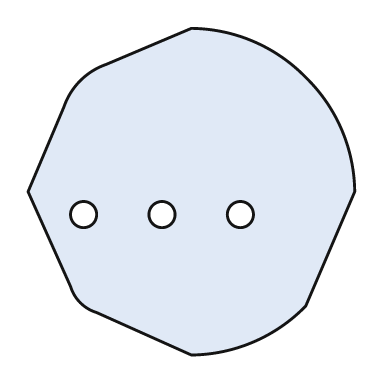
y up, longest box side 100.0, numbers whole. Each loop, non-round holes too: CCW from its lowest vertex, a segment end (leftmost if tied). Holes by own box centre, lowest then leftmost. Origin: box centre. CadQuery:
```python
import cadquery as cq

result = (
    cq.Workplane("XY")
    .moveTo(0.0, -50.0)
    .threePointArc((19.0, -46.0), (35.0, -35.0))
    .lineTo(50.0, 0.0)
    .threePointArc((46.0, 19.0), (35.0, 35.0))
    .threePointArc((19.0, 46.0), (0.0, 50.0))
    .lineTo(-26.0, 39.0)
    .threePointArc((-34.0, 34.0), (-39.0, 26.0))
    .lineTo(-50.0, 0.0)
    .lineTo(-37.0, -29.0)
    .threePointArc((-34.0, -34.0), (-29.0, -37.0))
    .close()
    .moveTo(-33.0, -7.0)
    .circle(4.0)
    .moveTo(-9.0, -7.0)
    .circle(4.0)
    .moveTo(15.0, -7.0)
    .circle(4.0)
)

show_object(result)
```